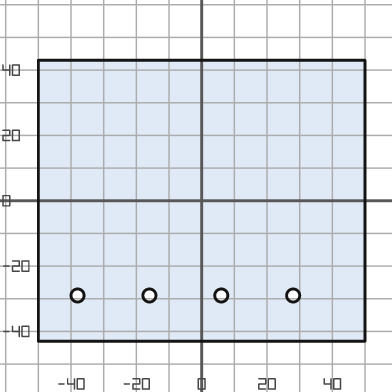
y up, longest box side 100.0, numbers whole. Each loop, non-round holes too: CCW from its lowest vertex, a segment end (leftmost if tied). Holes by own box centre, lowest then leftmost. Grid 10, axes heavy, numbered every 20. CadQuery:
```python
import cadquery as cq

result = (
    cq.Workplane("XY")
    .moveTo(-50.0, -43.0)
    .lineTo(50.0, -43.0)
    .lineTo(50.0, 43.0)
    .lineTo(-50.0, 43.0)
    .close()
    .moveTo(-38.0, -29.0)
    .circle(2.0)
    .moveTo(-16.0, -29.0)
    .circle(2.0)
    .moveTo(6.0, -29.0)
    .circle(2.0)
    .moveTo(28.0, -29.0)
    .circle(2.0)
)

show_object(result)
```